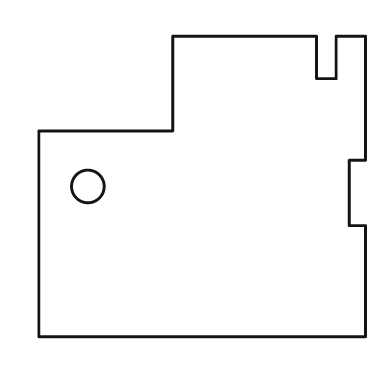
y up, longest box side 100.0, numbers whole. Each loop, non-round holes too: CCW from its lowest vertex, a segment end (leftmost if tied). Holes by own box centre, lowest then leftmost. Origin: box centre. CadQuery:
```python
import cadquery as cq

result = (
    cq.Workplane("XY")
    .moveTo(-50.0, -46.0)
    .lineTo(50.0, -46.0)
    .lineTo(50.0, -12.0)
    .lineTo(45.0, -12.0)
    .lineTo(45.0, 8.0)
    .lineTo(50.0, 8.0)
    .lineTo(50.0, 46.0)
    .lineTo(41.0, 46.0)
    .lineTo(41.0, 33.0)
    .lineTo(35.0, 33.0)
    .lineTo(35.0, 46.0)
    .lineTo(-9.0, 46.0)
    .lineTo(-9.0, 17.0)
    .lineTo(-50.0, 17.0)
    .close()
    .moveTo(-35.0, 0.0)
    .circle(5.0)
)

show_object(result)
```